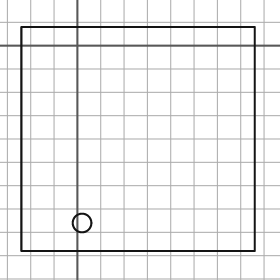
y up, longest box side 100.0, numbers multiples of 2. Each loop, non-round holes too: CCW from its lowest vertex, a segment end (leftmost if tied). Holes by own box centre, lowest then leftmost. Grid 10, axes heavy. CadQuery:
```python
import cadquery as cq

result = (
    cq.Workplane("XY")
    .moveTo(-24.0, -88.0)
    .lineTo(76.0, -88.0)
    .lineTo(76.0, 8.0)
    .lineTo(-24.0, 8.0)
    .close()
    .moveTo(2.0, -76.0)
    .circle(4.0)
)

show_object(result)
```